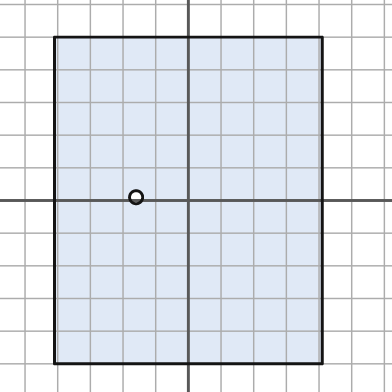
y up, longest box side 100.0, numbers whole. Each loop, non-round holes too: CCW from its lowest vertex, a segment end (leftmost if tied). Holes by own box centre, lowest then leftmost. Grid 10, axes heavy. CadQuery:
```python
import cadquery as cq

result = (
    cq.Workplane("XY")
    .moveTo(-41.0, -50.0)
    .lineTo(41.0, -50.0)
    .lineTo(41.0, 50.0)
    .lineTo(-41.0, 50.0)
    .close()
    .moveTo(-16.0, 1.0)
    .circle(2.0)
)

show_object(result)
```